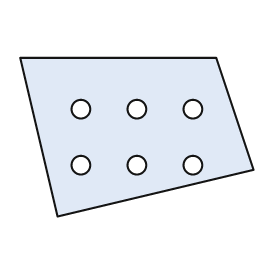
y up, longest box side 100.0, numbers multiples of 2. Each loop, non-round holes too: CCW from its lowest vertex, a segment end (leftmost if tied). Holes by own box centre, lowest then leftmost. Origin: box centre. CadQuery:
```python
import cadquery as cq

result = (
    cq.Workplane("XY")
    .moveTo(-34.0, -34.0)
    .lineTo(50.0, -14.0)
    .lineTo(34.0, 34.0)
    .lineTo(-50.0, 34.0)
    .close()
    .moveTo(-24.0, -12.0)
    .circle(4.0)
    .moveTo(0.0, -12.0)
    .circle(4.0)
    .moveTo(24.0, -12.0)
    .circle(4.0)
    .moveTo(-24.0, 12.0)
    .circle(4.0)
    .moveTo(0.0, 12.0)
    .circle(4.0)
    .moveTo(24.0, 12.0)
    .circle(4.0)
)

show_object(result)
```